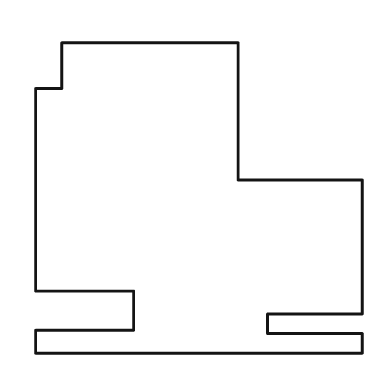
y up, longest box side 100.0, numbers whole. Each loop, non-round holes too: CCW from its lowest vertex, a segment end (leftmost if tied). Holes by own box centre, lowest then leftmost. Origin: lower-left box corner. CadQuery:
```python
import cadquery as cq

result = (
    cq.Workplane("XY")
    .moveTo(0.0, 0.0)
    .lineTo(100.0, 0.0)
    .lineTo(100.0, 6.0)
    .lineTo(71.0, 6.0)
    .lineTo(71.0, 12.0)
    .lineTo(100.0, 12.0)
    .lineTo(100.0, 53.0)
    .lineTo(62.0, 53.0)
    .lineTo(62.0, 95.0)
    .lineTo(8.0, 95.0)
    .lineTo(8.0, 81.0)
    .lineTo(0.0, 81.0)
    .lineTo(0.0, 19.0)
    .lineTo(30.0, 19.0)
    .lineTo(30.0, 7.0)
    .lineTo(0.0, 7.0)
    .close()
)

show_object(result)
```